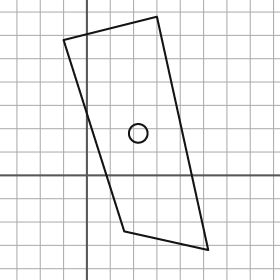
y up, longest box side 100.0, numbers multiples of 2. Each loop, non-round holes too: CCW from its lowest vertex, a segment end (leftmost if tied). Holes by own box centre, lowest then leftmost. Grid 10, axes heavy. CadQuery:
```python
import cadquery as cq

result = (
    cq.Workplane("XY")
    .moveTo(52.0, -32.0)
    .lineTo(30.0, 68.0)
    .lineTo(-10.0, 58.0)
    .lineTo(16.0, -24.0)
    .close()
    .moveTo(22.0, 18.0)
    .circle(4.0)
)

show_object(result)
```